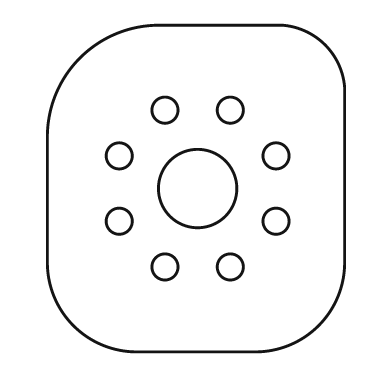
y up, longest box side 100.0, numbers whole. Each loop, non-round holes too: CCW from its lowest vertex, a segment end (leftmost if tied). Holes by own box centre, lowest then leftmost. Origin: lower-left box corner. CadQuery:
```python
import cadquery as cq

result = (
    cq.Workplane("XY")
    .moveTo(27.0, 0.0)
    .lineTo(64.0, 0.0)
    .threePointArc((83.0, 8.0), (91.0, 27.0))
    .lineTo(91.0, 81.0)
    .threePointArc((85.0, 94.0), (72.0, 100.0))
    .lineTo(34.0, 100.0)
    .threePointArc((10.0, 90.0), (0.0, 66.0))
    .lineTo(0.0, 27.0)
    .threePointArc((8.0, 8.0), (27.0, 0.0))
    .close()
    .moveTo(36.0, 26.0)
    .circle(4.0)
    .moveTo(56.0, 26.0)
    .circle(4.0)
    .moveTo(22.0, 40.0)
    .circle(4.0)
    .moveTo(70.0, 40.0)
    .circle(4.0)
    .moveTo(46.0, 50.0)
    .circle(12.0)
    .moveTo(22.0, 60.0)
    .circle(4.0)
    .moveTo(70.0, 60.0)
    .circle(4.0)
    .moveTo(36.0, 74.0)
    .circle(4.0)
    .moveTo(56.0, 74.0)
    .circle(4.0)
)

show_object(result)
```